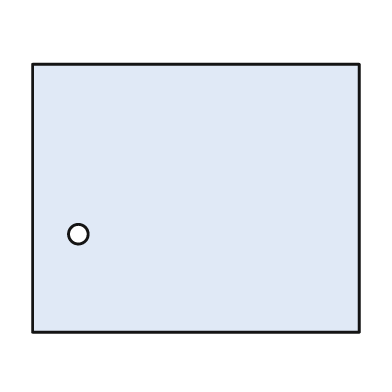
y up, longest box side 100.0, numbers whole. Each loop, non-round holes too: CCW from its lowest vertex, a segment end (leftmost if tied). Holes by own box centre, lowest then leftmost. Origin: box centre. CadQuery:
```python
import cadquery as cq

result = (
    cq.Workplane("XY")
    .moveTo(-50.0, -41.0)
    .lineTo(50.0, -41.0)
    .lineTo(50.0, 41.0)
    .lineTo(-50.0, 41.0)
    .close()
    .moveTo(-36.0, -11.0)
    .circle(3.0)
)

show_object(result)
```